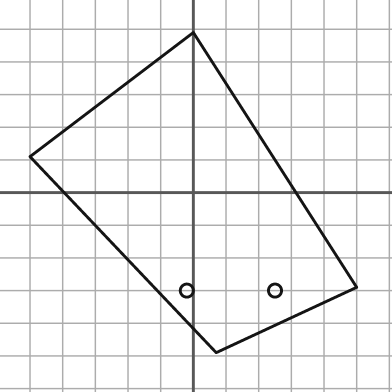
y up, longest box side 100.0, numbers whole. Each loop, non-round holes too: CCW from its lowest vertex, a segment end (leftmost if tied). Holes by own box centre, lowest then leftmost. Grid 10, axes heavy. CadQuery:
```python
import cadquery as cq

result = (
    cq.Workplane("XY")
    .moveTo(7.0, -49.0)
    .lineTo(50.0, -29.0)
    .lineTo(0.0, 49.0)
    .lineTo(-50.0, 11.0)
    .close()
    .moveTo(-2.0, -30.0)
    .circle(2.0)
    .moveTo(25.0, -30.0)
    .circle(2.0)
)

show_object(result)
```